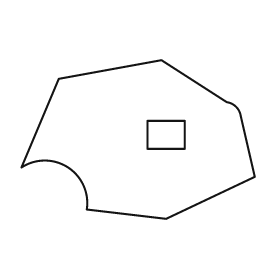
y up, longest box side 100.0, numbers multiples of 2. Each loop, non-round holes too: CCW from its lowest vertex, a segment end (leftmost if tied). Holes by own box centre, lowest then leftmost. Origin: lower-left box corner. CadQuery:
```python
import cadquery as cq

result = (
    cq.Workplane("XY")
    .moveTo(62.0, 0.0)
    .lineTo(100.0, 18.0)
    .lineTo(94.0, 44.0)
    .threePointArc((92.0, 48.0), (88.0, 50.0))
    .lineTo(60.0, 68.0)
    .lineTo(16.0, 60.0)
    .lineTo(0.0, 22.0)
    .threePointArc((20.0, 22.0), (28.0, 4.0))
    .close()
    .moveTo(54.0, 30.0)
    .lineTo(70.0, 30.0)
    .lineTo(70.0, 42.0)
    .lineTo(54.0, 42.0)
    .close()
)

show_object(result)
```